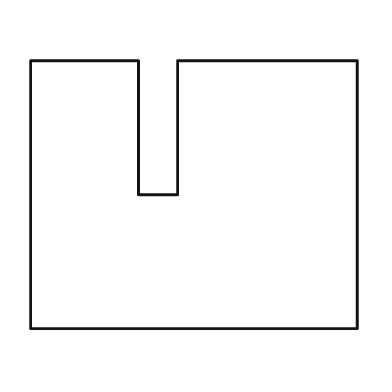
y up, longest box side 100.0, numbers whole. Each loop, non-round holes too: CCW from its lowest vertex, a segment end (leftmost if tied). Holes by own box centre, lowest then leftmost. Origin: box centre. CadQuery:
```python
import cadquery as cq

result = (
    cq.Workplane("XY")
    .moveTo(-50.0, -41.0)
    .lineTo(50.0, -41.0)
    .lineTo(50.0, 41.0)
    .lineTo(-5.0, 41.0)
    .lineTo(-5.0, 0.0)
    .lineTo(-17.0, 0.0)
    .lineTo(-17.0, 41.0)
    .lineTo(-50.0, 41.0)
    .close()
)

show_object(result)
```